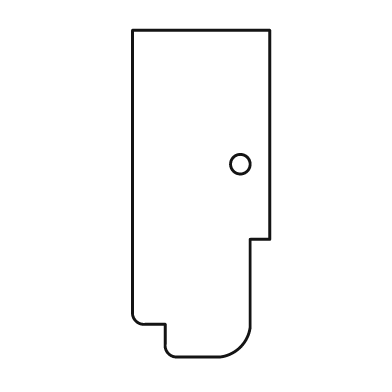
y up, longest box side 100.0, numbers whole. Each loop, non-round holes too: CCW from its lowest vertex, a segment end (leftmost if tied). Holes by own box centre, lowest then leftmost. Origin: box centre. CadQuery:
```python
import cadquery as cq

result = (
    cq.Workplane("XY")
    .moveTo(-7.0, -50.0)
    .lineTo(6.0, -50.0)
    .threePointArc((12.0, -47.0), (15.0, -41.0))
    .lineTo(15.0, -14.0)
    .lineTo(21.0, -14.0)
    .lineTo(21.0, 50.0)
    .lineTo(-21.0, 50.0)
    .lineTo(-21.0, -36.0)
    .threePointArc((-20.0, -39.0), (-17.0, -40.0))
    .lineTo(-11.0, -40.0)
    .lineTo(-11.0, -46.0)
    .threePointArc((-10.0, -49.0), (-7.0, -50.0))
    .close()
    .moveTo(12.0, 9.0)
    .circle(3.0)
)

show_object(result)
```